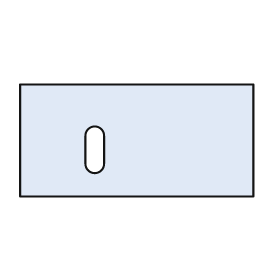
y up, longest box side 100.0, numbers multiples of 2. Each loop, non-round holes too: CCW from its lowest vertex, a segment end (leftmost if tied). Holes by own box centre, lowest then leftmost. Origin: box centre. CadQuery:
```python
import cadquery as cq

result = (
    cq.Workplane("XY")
    .moveTo(-50.0, -24.0)
    .lineTo(50.0, -24.0)
    .lineTo(50.0, 24.0)
    .lineTo(-50.0, 24.0)
    .close()
    .moveTo(-22.0, -10.0)
    .threePointArc((-18.0, -14.0), (-14.0, -10.0))
    .lineTo(-14.0, 2.0)
    .threePointArc((-18.0, 6.0), (-22.0, 2.0))
    .close()
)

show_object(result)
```